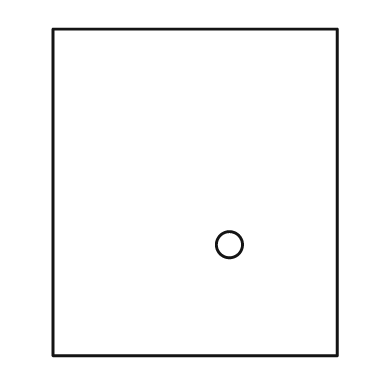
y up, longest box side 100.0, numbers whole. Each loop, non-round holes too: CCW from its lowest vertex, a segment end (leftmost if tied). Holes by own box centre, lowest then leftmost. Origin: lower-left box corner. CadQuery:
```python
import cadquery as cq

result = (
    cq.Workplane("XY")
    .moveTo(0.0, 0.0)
    .lineTo(87.0, 0.0)
    .lineTo(87.0, 100.0)
    .lineTo(0.0, 100.0)
    .close()
    .moveTo(54.0, 34.0)
    .circle(4.0)
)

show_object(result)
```